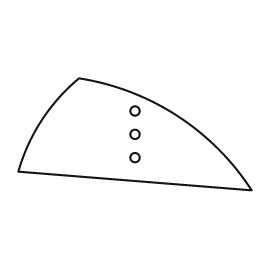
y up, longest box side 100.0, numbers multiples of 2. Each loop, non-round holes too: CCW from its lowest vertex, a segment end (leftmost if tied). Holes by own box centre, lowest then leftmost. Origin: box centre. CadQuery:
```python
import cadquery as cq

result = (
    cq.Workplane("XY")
    .moveTo(50.0, -24.0)
    .threePointArc((18.0, 8.0), (-24.0, 24.0))
    .threePointArc((-40.0, 6.0), (-50.0, -16.0))
    .close()
    .moveTo(0.0, -10.0)
    .circle(2.0)
    .moveTo(0.0, 0.0)
    .circle(2.0)
    .moveTo(0.0, 10.0)
    .circle(2.0)
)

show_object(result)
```